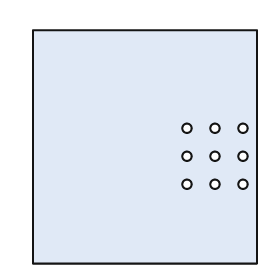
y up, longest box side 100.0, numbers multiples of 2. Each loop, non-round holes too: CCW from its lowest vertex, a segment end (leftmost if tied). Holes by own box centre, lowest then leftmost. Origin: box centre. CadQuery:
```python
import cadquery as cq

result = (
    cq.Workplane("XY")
    .moveTo(-48.0, -50.0)
    .lineTo(48.0, -50.0)
    .lineTo(48.0, 50.0)
    .lineTo(-48.0, 50.0)
    .close()
    .moveTo(18.0, -16.0)
    .circle(2.0)
    .moveTo(30.0, -16.0)
    .circle(2.0)
    .moveTo(42.0, -16.0)
    .circle(2.0)
    .moveTo(18.0, -4.0)
    .circle(2.0)
    .moveTo(30.0, -4.0)
    .circle(2.0)
    .moveTo(42.0, -4.0)
    .circle(2.0)
    .moveTo(18.0, 8.0)
    .circle(2.0)
    .moveTo(30.0, 8.0)
    .circle(2.0)
    .moveTo(42.0, 8.0)
    .circle(2.0)
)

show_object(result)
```